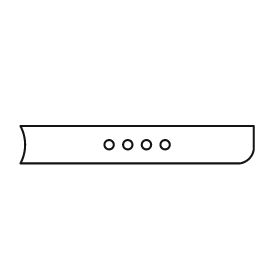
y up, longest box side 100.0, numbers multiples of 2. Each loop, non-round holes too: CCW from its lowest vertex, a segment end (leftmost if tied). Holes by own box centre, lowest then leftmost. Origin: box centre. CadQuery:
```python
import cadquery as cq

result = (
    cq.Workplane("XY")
    .moveTo(-50.0, -8.0)
    .lineTo(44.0, -8.0)
    .threePointArc((48.0, -6.0), (50.0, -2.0))
    .lineTo(50.0, 8.0)
    .lineTo(-50.0, 8.0)
    .threePointArc((-48.0, 0.0), (-50.0, -8.0))
    .close()
    .moveTo(-12.0, 0.0)
    .circle(2.0)
    .moveTo(-4.0, 0.0)
    .circle(2.0)
    .moveTo(4.0, 0.0)
    .circle(2.0)
    .moveTo(12.0, 0.0)
    .circle(2.0)
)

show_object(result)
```